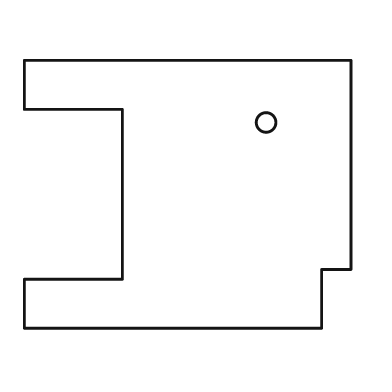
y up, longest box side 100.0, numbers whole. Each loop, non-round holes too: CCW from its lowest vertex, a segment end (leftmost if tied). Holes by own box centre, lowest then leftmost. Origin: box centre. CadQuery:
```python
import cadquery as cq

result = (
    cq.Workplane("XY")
    .moveTo(-50.0, -41.0)
    .lineTo(41.0, -41.0)
    .lineTo(41.0, -23.0)
    .lineTo(50.0, -23.0)
    .lineTo(50.0, 41.0)
    .lineTo(-50.0, 41.0)
    .lineTo(-50.0, 26.0)
    .lineTo(-20.0, 26.0)
    .lineTo(-20.0, -26.0)
    .lineTo(-50.0, -26.0)
    .close()
    .moveTo(24.0, 22.0)
    .circle(3.0)
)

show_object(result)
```